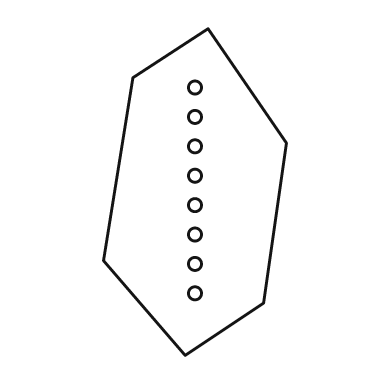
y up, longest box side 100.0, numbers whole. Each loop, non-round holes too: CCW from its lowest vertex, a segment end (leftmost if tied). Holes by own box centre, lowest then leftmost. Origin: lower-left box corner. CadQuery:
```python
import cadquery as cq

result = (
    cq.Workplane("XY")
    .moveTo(25.0, 0.0)
    .lineTo(49.0, 16.0)
    .lineTo(56.0, 65.0)
    .lineTo(32.0, 100.0)
    .lineTo(9.0, 85.0)
    .lineTo(0.0, 29.0)
    .close()
    .moveTo(28.0, 19.0)
    .circle(2.0)
    .moveTo(28.0, 28.0)
    .circle(2.0)
    .moveTo(28.0, 37.0)
    .circle(2.0)
    .moveTo(28.0, 46.0)
    .circle(2.0)
    .moveTo(28.0, 55.0)
    .circle(2.0)
    .moveTo(28.0, 64.0)
    .circle(2.0)
    .moveTo(28.0, 73.0)
    .circle(2.0)
    .moveTo(28.0, 82.0)
    .circle(2.0)
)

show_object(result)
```